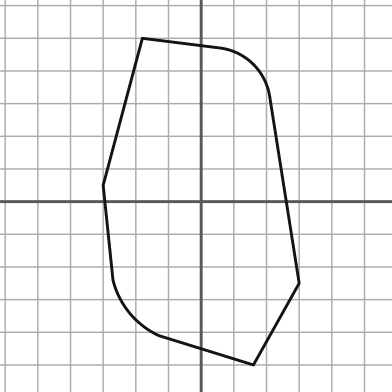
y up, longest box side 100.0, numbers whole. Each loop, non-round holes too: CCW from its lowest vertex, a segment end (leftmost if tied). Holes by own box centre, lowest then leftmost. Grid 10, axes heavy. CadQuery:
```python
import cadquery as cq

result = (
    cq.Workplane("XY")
    .moveTo(16.0, -50.0)
    .lineTo(30.0, -25.0)
    .lineTo(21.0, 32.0)
    .threePointArc((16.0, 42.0), (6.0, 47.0))
    .lineTo(-18.0, 50.0)
    .lineTo(-30.0, 5.0)
    .lineTo(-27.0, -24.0)
    .threePointArc((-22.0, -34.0), (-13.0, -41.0))
    .close()
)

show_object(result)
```